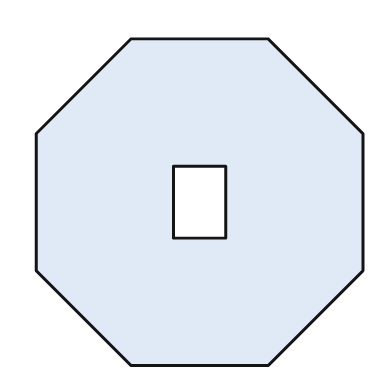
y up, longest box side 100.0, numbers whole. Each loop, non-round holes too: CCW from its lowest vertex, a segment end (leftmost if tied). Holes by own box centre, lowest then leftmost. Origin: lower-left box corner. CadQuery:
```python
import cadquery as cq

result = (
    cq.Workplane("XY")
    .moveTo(29.0, 0.0)
    .lineTo(71.0, 0.0)
    .lineTo(100.0, 29.0)
    .lineTo(100.0, 71.0)
    .lineTo(71.0, 100.0)
    .lineTo(29.0, 100.0)
    .lineTo(0.0, 71.0)
    .lineTo(0.0, 29.0)
    .close()
    .moveTo(42.0, 39.0)
    .lineTo(58.0, 39.0)
    .lineTo(58.0, 61.0)
    .lineTo(42.0, 61.0)
    .close()
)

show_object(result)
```